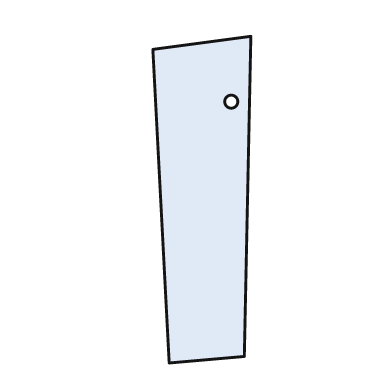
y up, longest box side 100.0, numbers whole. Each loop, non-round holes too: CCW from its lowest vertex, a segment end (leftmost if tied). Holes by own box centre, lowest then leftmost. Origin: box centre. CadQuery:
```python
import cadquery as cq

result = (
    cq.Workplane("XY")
    .moveTo(-10.0, -50.0)
    .lineTo(13.0, -48.0)
    .lineTo(15.0, 50.0)
    .lineTo(-15.0, 46.0)
    .close()
    .moveTo(9.0, 30.0)
    .circle(2.0)
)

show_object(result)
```